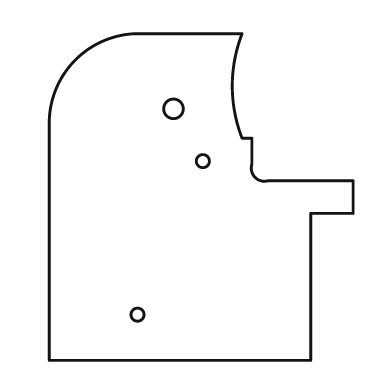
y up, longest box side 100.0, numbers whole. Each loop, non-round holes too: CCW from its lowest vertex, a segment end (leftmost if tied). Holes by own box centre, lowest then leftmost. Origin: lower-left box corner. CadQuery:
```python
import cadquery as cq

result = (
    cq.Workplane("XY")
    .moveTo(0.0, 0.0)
    .lineTo(80.0, 0.0)
    .lineTo(80.0, 45.0)
    .lineTo(93.0, 45.0)
    .lineTo(93.0, 55.0)
    .lineTo(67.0, 55.0)
    .threePointArc((63.0, 56.0), (62.0, 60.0))
    .lineTo(62.0, 68.0)
    .lineTo(59.0, 68.0)
    .threePointArc((56.0, 84.0), (59.0, 100.0))
    .lineTo(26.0, 100.0)
    .threePointArc((8.0, 92.0), (0.0, 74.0))
    .close()
    .moveTo(27.0, 14.0)
    .circle(2.0)
    .moveTo(47.0, 61.0)
    .circle(2.0)
    .moveTo(38.0, 77.0)
    .circle(3.0)
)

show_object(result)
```